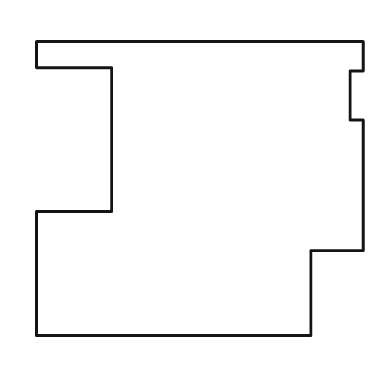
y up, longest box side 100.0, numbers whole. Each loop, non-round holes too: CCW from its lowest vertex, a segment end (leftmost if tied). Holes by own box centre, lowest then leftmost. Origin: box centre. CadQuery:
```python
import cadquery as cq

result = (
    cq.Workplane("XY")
    .moveTo(-50.0, -45.0)
    .lineTo(34.0, -45.0)
    .lineTo(34.0, -19.0)
    .lineTo(50.0, -19.0)
    .lineTo(50.0, 21.0)
    .lineTo(46.0, 21.0)
    .lineTo(46.0, 36.0)
    .lineTo(50.0, 36.0)
    .lineTo(50.0, 45.0)
    .lineTo(-50.0, 45.0)
    .lineTo(-50.0, 37.0)
    .lineTo(-27.0, 37.0)
    .lineTo(-27.0, -7.0)
    .lineTo(-50.0, -7.0)
    .close()
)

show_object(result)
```